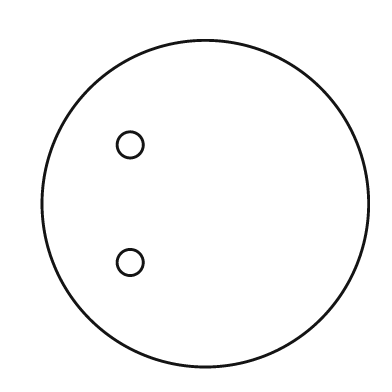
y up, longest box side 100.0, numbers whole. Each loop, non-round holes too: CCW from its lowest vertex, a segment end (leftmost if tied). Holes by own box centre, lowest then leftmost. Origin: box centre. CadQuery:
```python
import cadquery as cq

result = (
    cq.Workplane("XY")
    .moveTo(0.0, 0.0)
    .circle(50.0)
    .moveTo(-23.0, -18.0)
    .circle(4.0)
    .moveTo(-23.0, 18.0)
    .circle(4.0)
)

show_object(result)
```